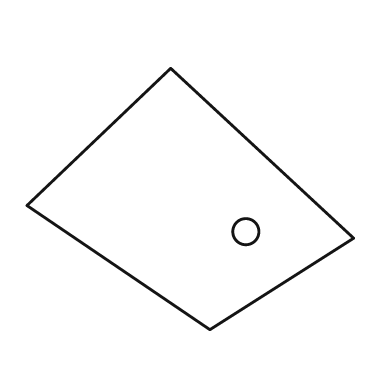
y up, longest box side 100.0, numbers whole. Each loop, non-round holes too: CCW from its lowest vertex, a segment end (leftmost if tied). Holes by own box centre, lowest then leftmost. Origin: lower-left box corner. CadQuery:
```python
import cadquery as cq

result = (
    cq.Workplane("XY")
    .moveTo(56.0, 0.0)
    .lineTo(100.0, 28.0)
    .lineTo(44.0, 80.0)
    .lineTo(0.0, 38.0)
    .close()
    .moveTo(67.0, 30.0)
    .circle(4.0)
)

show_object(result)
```